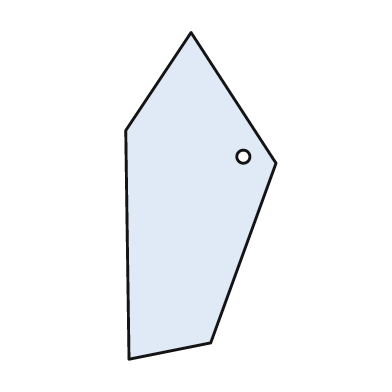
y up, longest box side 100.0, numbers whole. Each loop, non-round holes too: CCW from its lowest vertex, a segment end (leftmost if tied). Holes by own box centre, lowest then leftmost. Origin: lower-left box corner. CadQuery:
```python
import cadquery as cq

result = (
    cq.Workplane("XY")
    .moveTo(1.0, 0.0)
    .lineTo(26.0, 5.0)
    .lineTo(46.0, 60.0)
    .lineTo(20.0, 100.0)
    .lineTo(0.0, 70.0)
    .close()
    .moveTo(36.0, 62.0)
    .circle(2.0)
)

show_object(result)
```